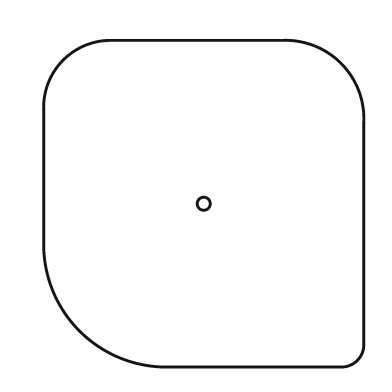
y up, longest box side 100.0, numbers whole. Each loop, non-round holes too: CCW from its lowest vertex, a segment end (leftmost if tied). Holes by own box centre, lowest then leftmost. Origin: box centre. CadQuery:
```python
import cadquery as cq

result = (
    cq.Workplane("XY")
    .moveTo(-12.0, -50.0)
    .lineTo(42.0, -50.0)
    .threePointArc((47.0, -48.0), (49.0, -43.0))
    .lineTo(49.0, 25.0)
    .threePointArc((42.0, 43.0), (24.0, 50.0))
    .lineTo(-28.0, 50.0)
    .threePointArc((-43.0, 44.0), (-49.0, 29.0))
    .lineTo(-49.0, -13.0)
    .threePointArc((-38.0, -39.0), (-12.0, -50.0))
    .close()
    .moveTo(0.0, 0.0)
    .circle(2.0)
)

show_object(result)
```